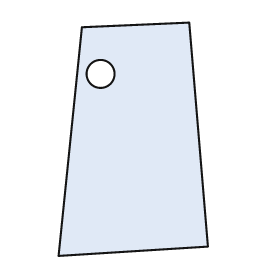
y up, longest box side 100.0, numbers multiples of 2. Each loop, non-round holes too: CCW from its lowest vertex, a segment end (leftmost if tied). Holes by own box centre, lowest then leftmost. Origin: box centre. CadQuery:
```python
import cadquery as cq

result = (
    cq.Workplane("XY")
    .moveTo(-32.0, -50.0)
    .lineTo(32.0, -46.0)
    .lineTo(24.0, 50.0)
    .lineTo(-22.0, 48.0)
    .close()
    .moveTo(-14.0, 28.0)
    .circle(6.0)
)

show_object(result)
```